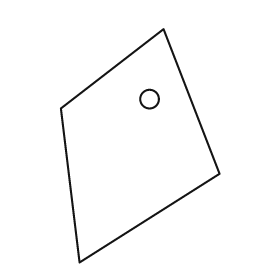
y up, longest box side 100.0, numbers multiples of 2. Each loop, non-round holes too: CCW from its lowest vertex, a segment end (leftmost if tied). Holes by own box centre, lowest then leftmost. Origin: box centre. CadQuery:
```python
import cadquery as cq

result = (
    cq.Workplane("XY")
    .moveTo(-26.0, -50.0)
    .lineTo(34.0, -12.0)
    .lineTo(10.0, 50.0)
    .lineTo(-34.0, 16.0)
    .close()
    .moveTo(4.0, 20.0)
    .circle(4.0)
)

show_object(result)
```